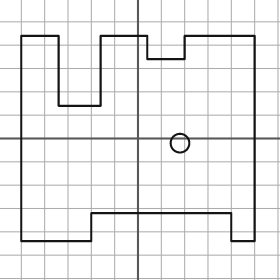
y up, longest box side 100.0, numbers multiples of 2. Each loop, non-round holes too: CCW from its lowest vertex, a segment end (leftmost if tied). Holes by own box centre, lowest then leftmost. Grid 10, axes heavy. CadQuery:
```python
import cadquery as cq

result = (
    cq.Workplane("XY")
    .moveTo(-50.0, -44.0)
    .lineTo(-20.0, -44.0)
    .lineTo(-20.0, -32.0)
    .lineTo(40.0, -32.0)
    .lineTo(40.0, -44.0)
    .lineTo(50.0, -44.0)
    .lineTo(50.0, 44.0)
    .lineTo(20.0, 44.0)
    .lineTo(20.0, 34.0)
    .lineTo(4.0, 34.0)
    .lineTo(4.0, 44.0)
    .lineTo(-16.0, 44.0)
    .lineTo(-16.0, 14.0)
    .lineTo(-34.0, 14.0)
    .lineTo(-34.0, 44.0)
    .lineTo(-50.0, 44.0)
    .close()
    .moveTo(18.0, -2.0)
    .circle(4.0)
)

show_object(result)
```